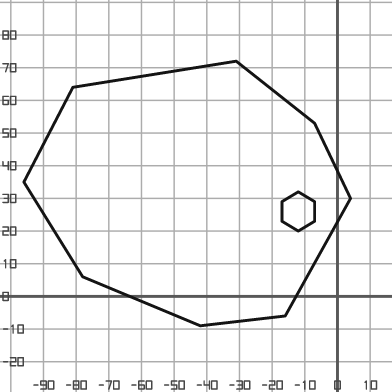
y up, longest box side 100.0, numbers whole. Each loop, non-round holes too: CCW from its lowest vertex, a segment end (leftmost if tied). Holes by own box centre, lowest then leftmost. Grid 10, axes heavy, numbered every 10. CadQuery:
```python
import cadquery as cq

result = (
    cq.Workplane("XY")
    .moveTo(-42.0, -9.0)
    .lineTo(-16.0, -6.0)
    .lineTo(4.0, 30.0)
    .lineTo(-7.0, 53.0)
    .lineTo(-31.0, 72.0)
    .lineTo(-81.0, 64.0)
    .lineTo(-96.0, 35.0)
    .lineTo(-78.0, 6.0)
    .close()
    .moveTo(-12.0, 20.0)
    .lineTo(-7.0, 23.0)
    .lineTo(-7.0, 29.0)
    .lineTo(-12.0, 32.0)
    .lineTo(-17.0, 29.0)
    .lineTo(-17.0, 23.0)
    .close()
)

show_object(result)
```